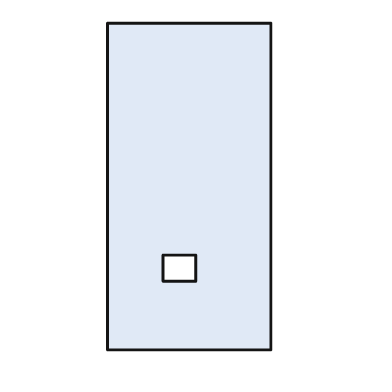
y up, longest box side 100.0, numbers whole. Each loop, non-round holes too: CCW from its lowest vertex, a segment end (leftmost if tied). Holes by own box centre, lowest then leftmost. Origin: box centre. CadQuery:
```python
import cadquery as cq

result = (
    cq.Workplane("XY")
    .moveTo(-25.0, -50.0)
    .lineTo(25.0, -50.0)
    .lineTo(25.0, 50.0)
    .lineTo(-25.0, 50.0)
    .close()
    .moveTo(-8.0, -29.0)
    .lineTo(2.0, -29.0)
    .lineTo(2.0, -21.0)
    .lineTo(-8.0, -21.0)
    .close()
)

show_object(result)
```